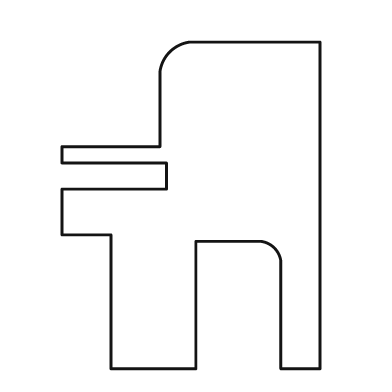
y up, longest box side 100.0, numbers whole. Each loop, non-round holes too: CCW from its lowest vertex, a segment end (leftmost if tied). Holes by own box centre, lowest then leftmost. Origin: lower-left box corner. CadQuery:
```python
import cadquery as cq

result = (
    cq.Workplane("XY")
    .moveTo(15.0, 0.0)
    .lineTo(41.0, 0.0)
    .lineTo(41.0, 39.0)
    .lineTo(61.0, 39.0)
    .threePointArc((65.0, 37.0), (67.0, 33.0))
    .lineTo(67.0, 0.0)
    .lineTo(79.0, 0.0)
    .lineTo(79.0, 100.0)
    .lineTo(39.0, 100.0)
    .threePointArc((33.0, 97.0), (30.0, 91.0))
    .lineTo(30.0, 68.0)
    .lineTo(0.0, 68.0)
    .lineTo(0.0, 63.0)
    .lineTo(32.0, 63.0)
    .lineTo(32.0, 55.0)
    .lineTo(0.0, 55.0)
    .lineTo(0.0, 41.0)
    .lineTo(15.0, 41.0)
    .close()
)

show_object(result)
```